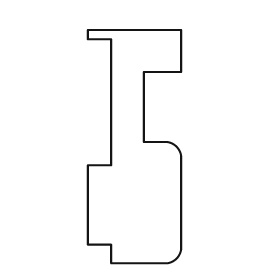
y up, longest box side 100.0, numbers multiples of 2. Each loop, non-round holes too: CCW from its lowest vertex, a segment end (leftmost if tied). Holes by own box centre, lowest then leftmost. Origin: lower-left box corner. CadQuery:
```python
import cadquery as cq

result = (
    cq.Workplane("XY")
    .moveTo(10.0, 0.0)
    .lineTo(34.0, 0.0)
    .threePointArc((38.0, 2.0), (40.0, 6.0))
    .lineTo(40.0, 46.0)
    .threePointArc((38.0, 50.0), (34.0, 52.0))
    .lineTo(24.0, 52.0)
    .lineTo(24.0, 82.0)
    .lineTo(40.0, 82.0)
    .lineTo(40.0, 100.0)
    .lineTo(0.0, 100.0)
    .lineTo(0.0, 96.0)
    .lineTo(10.0, 96.0)
    .lineTo(10.0, 42.0)
    .lineTo(0.0, 42.0)
    .lineTo(0.0, 8.0)
    .lineTo(10.0, 8.0)
    .close()
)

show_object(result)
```